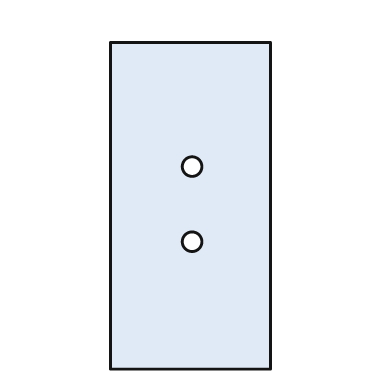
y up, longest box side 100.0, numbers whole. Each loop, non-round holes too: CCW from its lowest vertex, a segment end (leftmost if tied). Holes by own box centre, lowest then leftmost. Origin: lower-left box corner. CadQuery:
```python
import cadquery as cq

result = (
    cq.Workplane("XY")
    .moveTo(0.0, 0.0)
    .lineTo(49.0, 0.0)
    .lineTo(49.0, 100.0)
    .lineTo(0.0, 100.0)
    .close()
    .moveTo(25.0, 39.0)
    .circle(3.0)
    .moveTo(25.0, 62.0)
    .circle(3.0)
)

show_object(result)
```